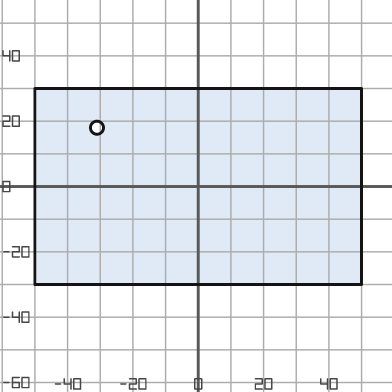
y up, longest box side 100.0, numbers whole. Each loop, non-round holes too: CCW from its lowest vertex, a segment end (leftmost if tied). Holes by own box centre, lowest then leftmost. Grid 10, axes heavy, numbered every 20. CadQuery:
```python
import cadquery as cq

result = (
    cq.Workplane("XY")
    .moveTo(-50.0, -30.0)
    .lineTo(50.0, -30.0)
    .lineTo(50.0, 30.0)
    .lineTo(-50.0, 30.0)
    .close()
    .moveTo(-31.0, 18.0)
    .circle(2.0)
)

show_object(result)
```